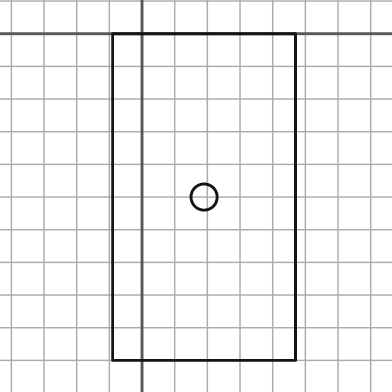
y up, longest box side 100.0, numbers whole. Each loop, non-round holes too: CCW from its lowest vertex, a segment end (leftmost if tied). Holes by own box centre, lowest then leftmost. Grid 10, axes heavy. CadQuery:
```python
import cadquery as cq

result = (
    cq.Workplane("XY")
    .moveTo(-9.0, -100.0)
    .lineTo(47.0, -100.0)
    .lineTo(47.0, 0.0)
    .lineTo(-9.0, 0.0)
    .close()
    .moveTo(19.0, -50.0)
    .circle(4.0)
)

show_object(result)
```